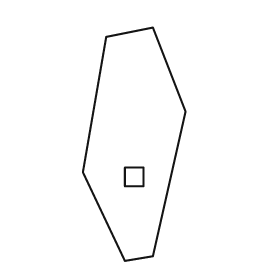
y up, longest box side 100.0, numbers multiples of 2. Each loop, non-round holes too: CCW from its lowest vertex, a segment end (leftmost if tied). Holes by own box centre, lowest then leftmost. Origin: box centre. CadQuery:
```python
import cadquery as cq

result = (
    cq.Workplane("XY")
    .moveTo(-4.0, -50.0)
    .lineTo(8.0, -48.0)
    .lineTo(22.0, 14.0)
    .lineTo(8.0, 50.0)
    .lineTo(-12.0, 46.0)
    .lineTo(-22.0, -12.0)
    .close()
    .moveTo(-4.0, -18.0)
    .lineTo(4.0, -18.0)
    .lineTo(4.0, -10.0)
    .lineTo(-4.0, -10.0)
    .close()
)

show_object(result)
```